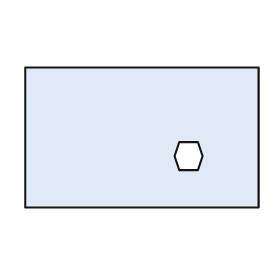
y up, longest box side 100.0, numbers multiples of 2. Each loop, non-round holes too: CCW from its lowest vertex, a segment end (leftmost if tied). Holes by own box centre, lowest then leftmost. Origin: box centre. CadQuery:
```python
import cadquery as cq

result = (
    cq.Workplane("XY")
    .moveTo(-50.0, -30.0)
    .lineTo(50.0, -30.0)
    .lineTo(50.0, 30.0)
    .lineTo(-50.0, 30.0)
    .close()
    .moveTo(16.0, -14.0)
    .lineTo(24.0, -14.0)
    .lineTo(26.0, -8.0)
    .lineTo(24.0, -2.0)
    .lineTo(16.0, -2.0)
    .lineTo(14.0, -8.0)
    .close()
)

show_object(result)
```